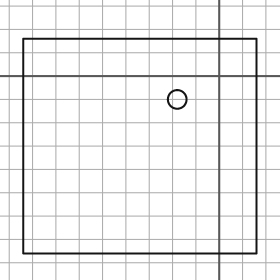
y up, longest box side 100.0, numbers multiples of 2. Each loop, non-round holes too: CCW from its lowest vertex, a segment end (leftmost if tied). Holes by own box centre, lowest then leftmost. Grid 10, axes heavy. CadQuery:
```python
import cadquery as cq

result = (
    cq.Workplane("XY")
    .moveTo(-84.0, -76.0)
    .lineTo(16.0, -76.0)
    .lineTo(16.0, 16.0)
    .lineTo(-84.0, 16.0)
    .close()
    .moveTo(-18.0, -10.0)
    .circle(4.0)
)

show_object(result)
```